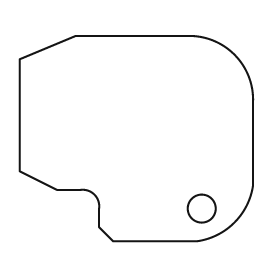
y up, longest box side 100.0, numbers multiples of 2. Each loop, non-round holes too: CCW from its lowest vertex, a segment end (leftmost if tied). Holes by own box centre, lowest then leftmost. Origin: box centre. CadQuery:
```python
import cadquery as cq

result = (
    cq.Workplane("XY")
    .moveTo(-10.0, -44.0)
    .lineTo(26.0, -44.0)
    .threePointArc((42.0, -36.0), (50.0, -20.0))
    .lineTo(50.0, 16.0)
    .threePointArc((42.0, 36.0), (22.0, 44.0))
    .lineTo(-26.0, 44.0)
    .lineTo(-50.0, 34.0)
    .lineTo(-50.0, -14.0)
    .lineTo(-34.0, -22.0)
    .lineTo(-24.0, -22.0)
    .threePointArc((-18.0, -24.0), (-16.0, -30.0))
    .lineTo(-16.0, -38.0)
    .close()
    .moveTo(28.0, -30.0)
    .circle(6.0)
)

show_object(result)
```